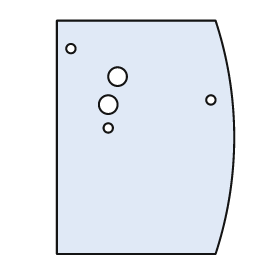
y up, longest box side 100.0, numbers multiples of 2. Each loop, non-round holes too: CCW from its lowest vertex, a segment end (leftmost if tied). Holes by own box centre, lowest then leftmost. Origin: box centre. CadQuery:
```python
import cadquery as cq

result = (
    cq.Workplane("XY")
    .moveTo(-38.0, -50.0)
    .lineTo(30.0, -50.0)
    .threePointArc((38.0, 0.0), (30.0, 50.0))
    .lineTo(-38.0, 50.0)
    .close()
    .moveTo(-16.0, 4.0)
    .circle(2.0)
    .moveTo(-16.0, 14.0)
    .circle(4.0)
    .moveTo(28.0, 16.0)
    .circle(2.0)
    .moveTo(-12.0, 26.0)
    .circle(4.0)
    .moveTo(-32.0, 38.0)
    .circle(2.0)
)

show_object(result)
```